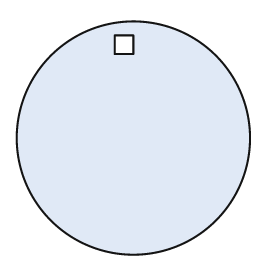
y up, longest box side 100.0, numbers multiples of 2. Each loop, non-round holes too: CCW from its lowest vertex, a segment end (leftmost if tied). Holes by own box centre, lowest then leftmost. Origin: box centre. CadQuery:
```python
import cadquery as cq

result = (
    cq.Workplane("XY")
    .moveTo(0.0, 0.0)
    .circle(50.0)
    .moveTo(-8.0, 36.0)
    .lineTo(0.0, 36.0)
    .lineTo(0.0, 44.0)
    .lineTo(-8.0, 44.0)
    .close()
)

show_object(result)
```